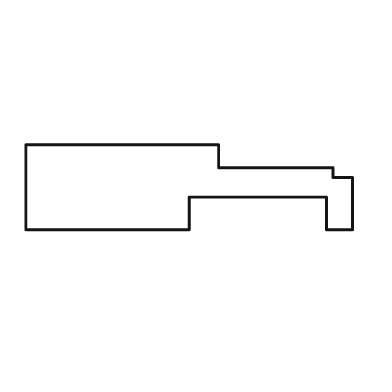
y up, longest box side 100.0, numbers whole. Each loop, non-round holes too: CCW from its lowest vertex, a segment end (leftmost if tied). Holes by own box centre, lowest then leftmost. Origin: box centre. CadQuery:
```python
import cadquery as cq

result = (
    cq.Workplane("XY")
    .moveTo(-50.0, -13.0)
    .lineTo(0.0, -13.0)
    .lineTo(0.0, -3.0)
    .lineTo(42.0, -3.0)
    .lineTo(42.0, -13.0)
    .lineTo(50.0, -13.0)
    .lineTo(50.0, 3.0)
    .lineTo(44.0, 3.0)
    .lineTo(44.0, 6.0)
    .lineTo(9.0, 6.0)
    .lineTo(9.0, 13.0)
    .lineTo(-50.0, 13.0)
    .close()
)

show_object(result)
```